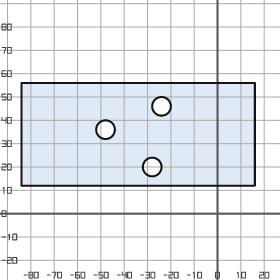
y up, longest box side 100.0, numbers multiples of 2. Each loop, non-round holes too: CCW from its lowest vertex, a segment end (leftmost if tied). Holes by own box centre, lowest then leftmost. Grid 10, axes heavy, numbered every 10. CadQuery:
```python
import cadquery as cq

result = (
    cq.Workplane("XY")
    .moveTo(-84.0, 12.0)
    .lineTo(16.0, 12.0)
    .lineTo(16.0, 56.0)
    .lineTo(-84.0, 56.0)
    .close()
    .moveTo(-28.0, 20.0)
    .circle(4.0)
    .moveTo(-48.0, 36.0)
    .circle(4.0)
    .moveTo(-24.0, 46.0)
    .circle(4.0)
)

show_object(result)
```